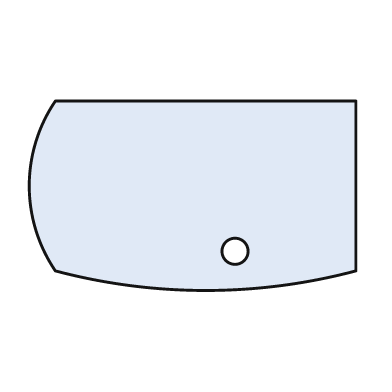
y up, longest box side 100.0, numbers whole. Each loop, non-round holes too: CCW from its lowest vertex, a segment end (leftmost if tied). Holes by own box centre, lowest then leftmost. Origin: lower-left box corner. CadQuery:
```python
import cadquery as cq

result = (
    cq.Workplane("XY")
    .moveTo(8.0, 6.0)
    .threePointArc((54.0, 0.0), (100.0, 6.0))
    .lineTo(100.0, 58.0)
    .lineTo(8.0, 58.0)
    .threePointArc((0.0, 32.0), (8.0, 6.0))
    .close()
    .moveTo(63.0, 12.0)
    .circle(4.0)
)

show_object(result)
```